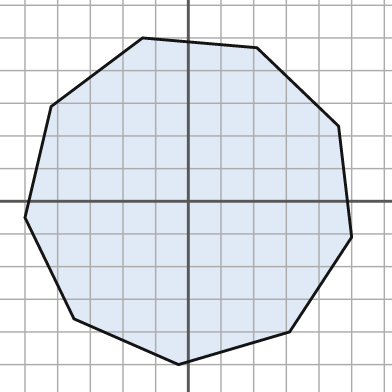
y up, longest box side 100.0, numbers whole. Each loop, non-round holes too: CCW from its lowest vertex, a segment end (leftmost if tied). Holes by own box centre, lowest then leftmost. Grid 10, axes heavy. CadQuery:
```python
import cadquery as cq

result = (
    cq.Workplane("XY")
    .moveTo(-3.0, -50.0)
    .lineTo(31.0, -40.0)
    .lineTo(50.0, -11.0)
    .lineTo(46.0, 23.0)
    .lineTo(21.0, 47.0)
    .lineTo(-14.0, 50.0)
    .lineTo(-42.0, 29.0)
    .lineTo(-50.0, -5.0)
    .lineTo(-35.0, -36.0)
    .close()
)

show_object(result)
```